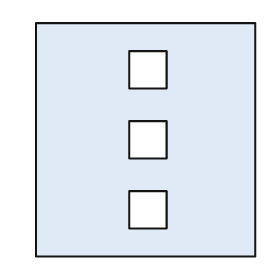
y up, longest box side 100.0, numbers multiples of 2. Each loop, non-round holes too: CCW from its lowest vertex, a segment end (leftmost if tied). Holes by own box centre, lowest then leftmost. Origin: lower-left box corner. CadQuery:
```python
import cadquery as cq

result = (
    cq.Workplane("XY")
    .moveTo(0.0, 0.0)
    .lineTo(94.0, 0.0)
    .lineTo(94.0, 100.0)
    .lineTo(0.0, 100.0)
    .close()
    .moveTo(40.0, 12.0)
    .lineTo(56.0, 12.0)
    .lineTo(56.0, 28.0)
    .lineTo(40.0, 28.0)
    .close()
    .moveTo(40.0, 42.0)
    .lineTo(56.0, 42.0)
    .lineTo(56.0, 58.0)
    .lineTo(40.0, 58.0)
    .close()
    .moveTo(40.0, 72.0)
    .lineTo(56.0, 72.0)
    .lineTo(56.0, 88.0)
    .lineTo(40.0, 88.0)
    .close()
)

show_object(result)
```